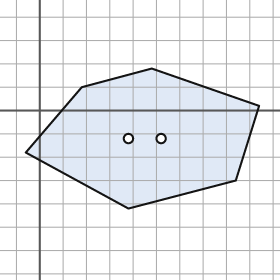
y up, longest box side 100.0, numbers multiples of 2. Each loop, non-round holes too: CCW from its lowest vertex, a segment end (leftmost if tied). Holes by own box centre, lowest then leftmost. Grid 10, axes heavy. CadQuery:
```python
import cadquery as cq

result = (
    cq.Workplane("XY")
    .moveTo(38.0, -42.0)
    .lineTo(84.0, -30.0)
    .lineTo(94.0, 2.0)
    .lineTo(48.0, 18.0)
    .lineTo(18.0, 10.0)
    .lineTo(-6.0, -18.0)
    .close()
    .moveTo(38.0, -12.0)
    .circle(2.0)
    .moveTo(52.0, -12.0)
    .circle(2.0)
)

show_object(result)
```